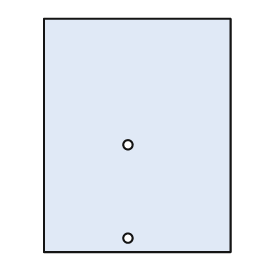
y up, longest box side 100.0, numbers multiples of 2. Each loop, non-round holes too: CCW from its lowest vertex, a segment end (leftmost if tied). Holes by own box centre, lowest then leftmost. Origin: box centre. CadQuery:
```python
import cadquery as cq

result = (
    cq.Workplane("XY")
    .moveTo(-40.0, -50.0)
    .lineTo(40.0, -50.0)
    .lineTo(40.0, 50.0)
    .lineTo(-40.0, 50.0)
    .close()
    .moveTo(-4.0, -44.0)
    .circle(2.0)
    .moveTo(-4.0, -4.0)
    .circle(2.0)
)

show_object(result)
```